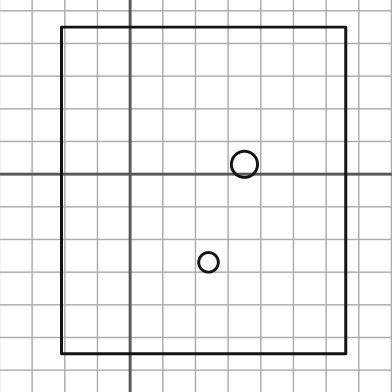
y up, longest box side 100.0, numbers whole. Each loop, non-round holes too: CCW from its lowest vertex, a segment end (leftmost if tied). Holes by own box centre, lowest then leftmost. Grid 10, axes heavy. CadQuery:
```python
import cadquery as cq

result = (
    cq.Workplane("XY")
    .moveTo(-21.0, -55.0)
    .lineTo(66.0, -55.0)
    .lineTo(66.0, 45.0)
    .lineTo(-21.0, 45.0)
    .close()
    .moveTo(24.0, -27.0)
    .circle(3.0)
    .moveTo(35.0, 3.0)
    .circle(4.0)
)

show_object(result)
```